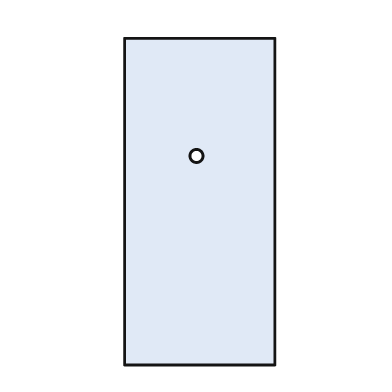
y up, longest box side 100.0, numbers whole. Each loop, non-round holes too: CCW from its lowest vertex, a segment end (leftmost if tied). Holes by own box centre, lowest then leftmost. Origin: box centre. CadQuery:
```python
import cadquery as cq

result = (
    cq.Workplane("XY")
    .moveTo(-23.0, -50.0)
    .lineTo(23.0, -50.0)
    .lineTo(23.0, 50.0)
    .lineTo(-23.0, 50.0)
    .close()
    .moveTo(-1.0, 14.0)
    .circle(2.0)
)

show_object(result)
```